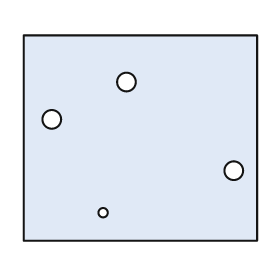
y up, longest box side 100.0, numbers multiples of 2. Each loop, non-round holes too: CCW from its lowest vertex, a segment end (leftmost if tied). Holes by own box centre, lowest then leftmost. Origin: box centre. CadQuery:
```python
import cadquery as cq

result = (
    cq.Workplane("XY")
    .moveTo(-50.0, -44.0)
    .lineTo(50.0, -44.0)
    .lineTo(50.0, 44.0)
    .lineTo(-50.0, 44.0)
    .close()
    .moveTo(-16.0, -32.0)
    .circle(2.0)
    .moveTo(40.0, -14.0)
    .circle(4.0)
    .moveTo(-38.0, 8.0)
    .circle(4.0)
    .moveTo(-6.0, 24.0)
    .circle(4.0)
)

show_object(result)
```